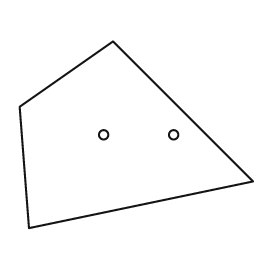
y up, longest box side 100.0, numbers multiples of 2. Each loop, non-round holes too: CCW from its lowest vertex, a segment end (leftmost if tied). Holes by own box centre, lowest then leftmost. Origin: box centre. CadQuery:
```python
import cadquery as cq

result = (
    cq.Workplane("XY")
    .moveTo(-46.0, -40.0)
    .lineTo(50.0, -20.0)
    .lineTo(-10.0, 40.0)
    .lineTo(-50.0, 12.0)
    .close()
    .moveTo(-14.0, 0.0)
    .circle(2.0)
    .moveTo(16.0, 0.0)
    .circle(2.0)
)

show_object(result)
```